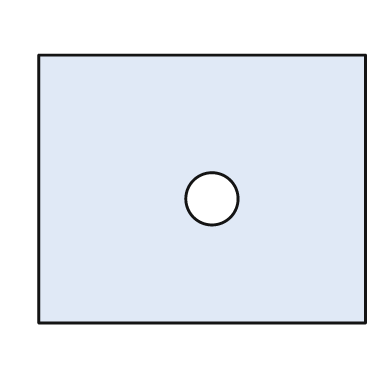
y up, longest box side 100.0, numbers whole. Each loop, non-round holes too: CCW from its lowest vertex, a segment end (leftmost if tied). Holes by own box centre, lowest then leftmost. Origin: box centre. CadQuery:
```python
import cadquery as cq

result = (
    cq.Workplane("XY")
    .moveTo(-50.0, -41.0)
    .lineTo(50.0, -41.0)
    .lineTo(50.0, 41.0)
    .lineTo(-50.0, 41.0)
    .close()
    .moveTo(3.0, -3.0)
    .circle(8.0)
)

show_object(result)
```